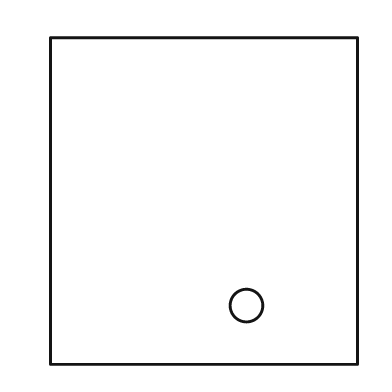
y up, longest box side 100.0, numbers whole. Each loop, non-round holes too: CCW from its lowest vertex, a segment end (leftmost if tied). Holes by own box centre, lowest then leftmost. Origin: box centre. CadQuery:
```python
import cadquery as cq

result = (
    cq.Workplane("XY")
    .moveTo(-47.0, -50.0)
    .lineTo(47.0, -50.0)
    .lineTo(47.0, 50.0)
    .lineTo(-47.0, 50.0)
    .close()
    .moveTo(13.0, -32.0)
    .circle(5.0)
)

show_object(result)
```